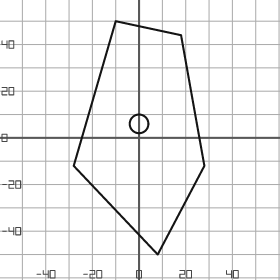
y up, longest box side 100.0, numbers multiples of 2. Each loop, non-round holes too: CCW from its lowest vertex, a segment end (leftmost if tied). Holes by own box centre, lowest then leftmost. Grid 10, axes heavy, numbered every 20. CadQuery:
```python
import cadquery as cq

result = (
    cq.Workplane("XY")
    .moveTo(8.0, -50.0)
    .lineTo(28.0, -12.0)
    .lineTo(18.0, 44.0)
    .lineTo(-10.0, 50.0)
    .lineTo(-28.0, -12.0)
    .close()
    .moveTo(0.0, 6.0)
    .circle(4.0)
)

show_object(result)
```